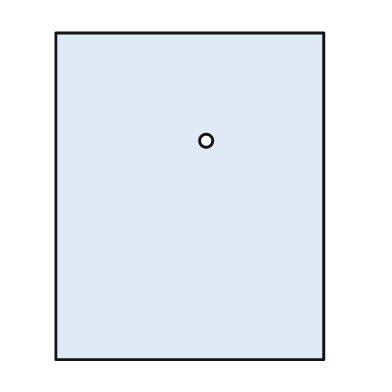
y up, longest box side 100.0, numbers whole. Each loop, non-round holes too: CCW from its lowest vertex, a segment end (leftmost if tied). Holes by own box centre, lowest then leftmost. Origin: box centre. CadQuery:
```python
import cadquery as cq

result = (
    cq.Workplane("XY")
    .moveTo(-41.0, -50.0)
    .lineTo(41.0, -50.0)
    .lineTo(41.0, 50.0)
    .lineTo(-41.0, 50.0)
    .close()
    .moveTo(5.0, 17.0)
    .circle(2.0)
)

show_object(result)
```